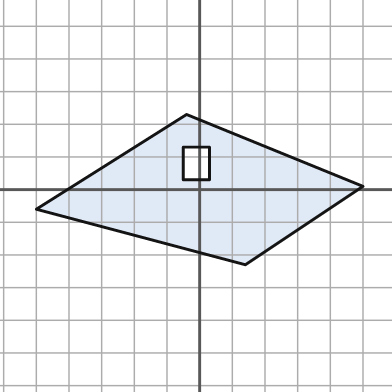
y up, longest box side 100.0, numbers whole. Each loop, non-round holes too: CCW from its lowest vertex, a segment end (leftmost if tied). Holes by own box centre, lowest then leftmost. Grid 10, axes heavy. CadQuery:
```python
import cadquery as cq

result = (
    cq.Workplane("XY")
    .moveTo(14.0, -23.0)
    .lineTo(50.0, 1.0)
    .lineTo(-4.0, 23.0)
    .lineTo(-50.0, -6.0)
    .close()
    .moveTo(-5.0, 3.0)
    .lineTo(3.0, 3.0)
    .lineTo(3.0, 13.0)
    .lineTo(-5.0, 13.0)
    .close()
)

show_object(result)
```